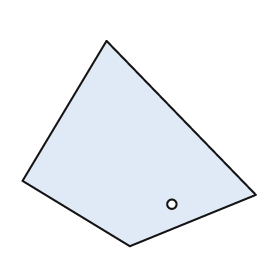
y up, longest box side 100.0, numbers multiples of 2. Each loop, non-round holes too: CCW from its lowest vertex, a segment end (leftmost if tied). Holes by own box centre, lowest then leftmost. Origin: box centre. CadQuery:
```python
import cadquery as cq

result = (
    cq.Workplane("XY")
    .moveTo(-4.0, -44.0)
    .lineTo(50.0, -22.0)
    .lineTo(-14.0, 44.0)
    .lineTo(-50.0, -16.0)
    .close()
    .moveTo(14.0, -26.0)
    .circle(2.0)
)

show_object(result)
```